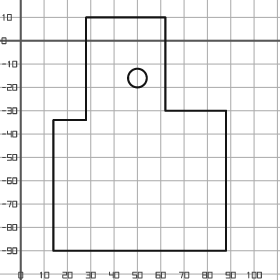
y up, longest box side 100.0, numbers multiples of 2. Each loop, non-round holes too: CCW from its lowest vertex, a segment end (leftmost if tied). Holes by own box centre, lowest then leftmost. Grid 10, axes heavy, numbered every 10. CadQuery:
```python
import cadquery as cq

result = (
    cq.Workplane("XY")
    .moveTo(14.0, -90.0)
    .lineTo(88.0, -90.0)
    .lineTo(88.0, -30.0)
    .lineTo(62.0, -30.0)
    .lineTo(62.0, 10.0)
    .lineTo(28.0, 10.0)
    .lineTo(28.0, -34.0)
    .lineTo(14.0, -34.0)
    .close()
    .moveTo(50.0, -16.0)
    .circle(4.0)
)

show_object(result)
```